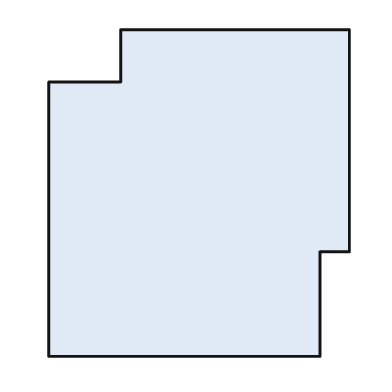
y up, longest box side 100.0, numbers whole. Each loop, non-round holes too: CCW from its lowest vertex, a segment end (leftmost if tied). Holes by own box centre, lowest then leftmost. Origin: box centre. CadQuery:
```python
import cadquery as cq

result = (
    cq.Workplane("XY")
    .moveTo(-46.0, -50.0)
    .lineTo(37.0, -50.0)
    .lineTo(37.0, -18.0)
    .lineTo(46.0, -18.0)
    .lineTo(46.0, 50.0)
    .lineTo(-24.0, 50.0)
    .lineTo(-24.0, 34.0)
    .lineTo(-46.0, 34.0)
    .close()
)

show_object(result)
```